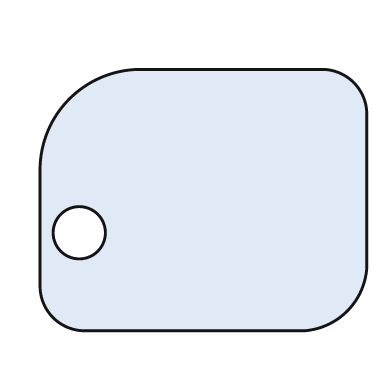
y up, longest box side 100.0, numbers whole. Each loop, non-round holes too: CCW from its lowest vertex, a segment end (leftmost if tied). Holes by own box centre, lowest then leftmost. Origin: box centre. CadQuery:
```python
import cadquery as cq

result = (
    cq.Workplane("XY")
    .moveTo(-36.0, -40.0)
    .lineTo(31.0, -40.0)
    .threePointArc((44.0, -34.0), (50.0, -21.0))
    .lineTo(50.0, 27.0)
    .threePointArc((46.0, 36.0), (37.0, 40.0))
    .lineTo(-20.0, 40.0)
    .threePointArc((-41.0, 31.0), (-50.0, 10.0))
    .lineTo(-50.0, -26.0)
    .threePointArc((-46.0, -36.0), (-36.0, -40.0))
    .close()
    .moveTo(-38.0, -10.0)
    .circle(8.0)
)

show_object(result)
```